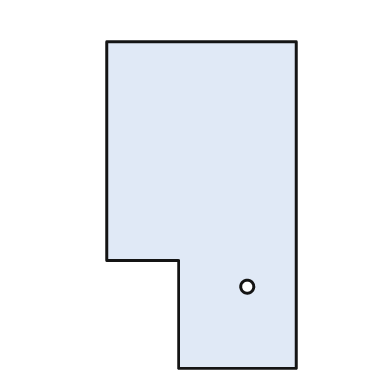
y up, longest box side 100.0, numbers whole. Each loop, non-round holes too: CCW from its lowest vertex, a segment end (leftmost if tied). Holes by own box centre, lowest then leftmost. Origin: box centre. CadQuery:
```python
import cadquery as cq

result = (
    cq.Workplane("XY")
    .moveTo(-7.0, -50.0)
    .lineTo(29.0, -50.0)
    .lineTo(29.0, 50.0)
    .lineTo(-29.0, 50.0)
    .lineTo(-29.0, -17.0)
    .lineTo(-7.0, -17.0)
    .close()
    .moveTo(14.0, -25.0)
    .circle(2.0)
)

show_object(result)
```